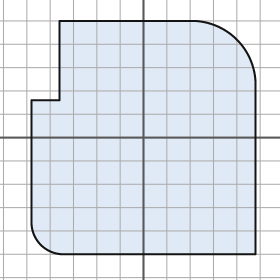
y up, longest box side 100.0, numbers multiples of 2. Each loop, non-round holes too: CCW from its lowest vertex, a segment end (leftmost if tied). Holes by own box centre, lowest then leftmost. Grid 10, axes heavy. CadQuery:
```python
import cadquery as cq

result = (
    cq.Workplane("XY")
    .moveTo(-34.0, -50.0)
    .lineTo(48.0, -50.0)
    .lineTo(48.0, 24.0)
    .threePointArc((40.0, 42.0), (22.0, 50.0))
    .lineTo(-36.0, 50.0)
    .lineTo(-36.0, 16.0)
    .lineTo(-48.0, 16.0)
    .lineTo(-48.0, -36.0)
    .threePointArc((-44.0, -46.0), (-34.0, -50.0))
    .close()
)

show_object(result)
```